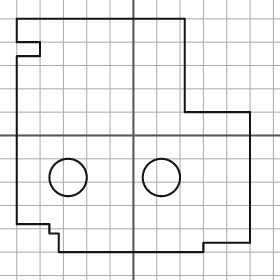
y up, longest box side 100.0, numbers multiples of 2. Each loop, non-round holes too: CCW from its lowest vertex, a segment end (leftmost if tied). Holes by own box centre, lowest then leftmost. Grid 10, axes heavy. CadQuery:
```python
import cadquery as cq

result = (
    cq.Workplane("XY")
    .moveTo(-32.0, -50.0)
    .lineTo(30.0, -50.0)
    .lineTo(30.0, -46.0)
    .lineTo(50.0, -46.0)
    .lineTo(50.0, 10.0)
    .lineTo(22.0, 10.0)
    .lineTo(22.0, 50.0)
    .lineTo(-50.0, 50.0)
    .lineTo(-50.0, 40.0)
    .lineTo(-40.0, 40.0)
    .lineTo(-40.0, 34.0)
    .lineTo(-50.0, 34.0)
    .lineTo(-50.0, -38.0)
    .lineTo(-36.0, -38.0)
    .lineTo(-36.0, -42.0)
    .lineTo(-32.0, -42.0)
    .close()
    .moveTo(-28.0, -18.0)
    .circle(8.0)
    .moveTo(12.0, -18.0)
    .circle(8.0)
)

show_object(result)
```